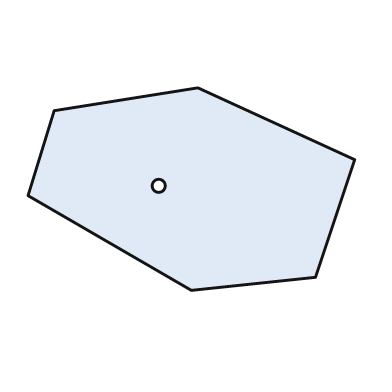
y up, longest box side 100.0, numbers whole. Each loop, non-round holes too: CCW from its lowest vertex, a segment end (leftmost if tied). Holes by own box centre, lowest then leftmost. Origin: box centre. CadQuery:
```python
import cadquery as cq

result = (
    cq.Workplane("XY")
    .moveTo(0.0, -31.0)
    .lineTo(38.0, -27.0)
    .lineTo(50.0, 9.0)
    .lineTo(2.0, 31.0)
    .lineTo(-42.0, 24.0)
    .lineTo(-50.0, -2.0)
    .close()
    .moveTo(-10.0, 1.0)
    .circle(2.0)
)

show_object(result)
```